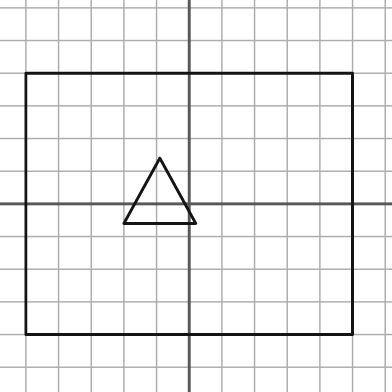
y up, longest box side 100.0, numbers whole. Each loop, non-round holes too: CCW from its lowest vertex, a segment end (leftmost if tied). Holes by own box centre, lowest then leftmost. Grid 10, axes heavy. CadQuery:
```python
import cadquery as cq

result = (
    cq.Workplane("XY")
    .moveTo(-50.0, -40.0)
    .lineTo(50.0, -40.0)
    .lineTo(50.0, 40.0)
    .lineTo(-50.0, 40.0)
    .close()
    .moveTo(-20.0, -6.0)
    .lineTo(2.0, -6.0)
    .lineTo(-9.0, 14.0)
    .close()
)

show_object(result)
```